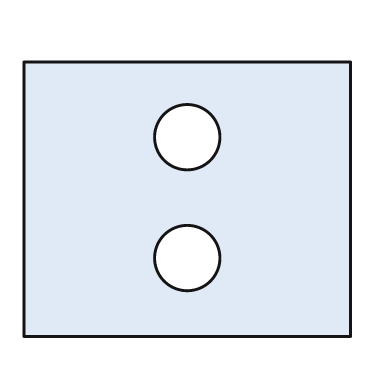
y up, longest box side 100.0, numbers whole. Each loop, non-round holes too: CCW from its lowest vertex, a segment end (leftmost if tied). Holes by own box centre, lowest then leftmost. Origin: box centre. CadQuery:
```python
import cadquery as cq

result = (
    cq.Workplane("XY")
    .moveTo(-50.0, -42.0)
    .lineTo(50.0, -42.0)
    .lineTo(50.0, 42.0)
    .lineTo(-50.0, 42.0)
    .close()
    .moveTo(0.0, -18.0)
    .circle(10.0)
    .moveTo(0.0, 19.0)
    .circle(10.0)
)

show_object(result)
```